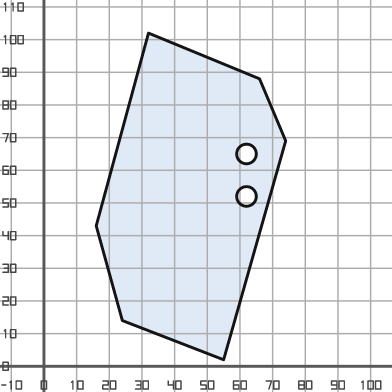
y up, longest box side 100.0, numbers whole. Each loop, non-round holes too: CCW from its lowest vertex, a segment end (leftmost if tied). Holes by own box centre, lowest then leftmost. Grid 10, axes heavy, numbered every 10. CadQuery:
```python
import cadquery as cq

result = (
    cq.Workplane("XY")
    .moveTo(55.0, 2.0)
    .lineTo(74.0, 69.0)
    .lineTo(66.0, 88.0)
    .lineTo(32.0, 102.0)
    .lineTo(16.0, 43.0)
    .lineTo(24.0, 14.0)
    .close()
    .moveTo(62.0, 52.0)
    .circle(3.0)
    .moveTo(62.0, 65.0)
    .circle(3.0)
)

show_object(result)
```